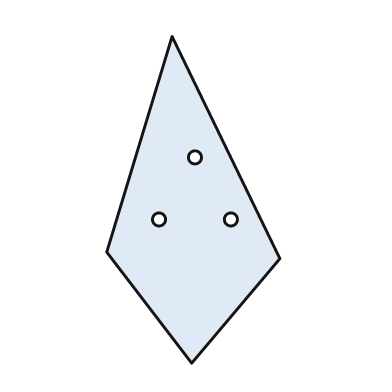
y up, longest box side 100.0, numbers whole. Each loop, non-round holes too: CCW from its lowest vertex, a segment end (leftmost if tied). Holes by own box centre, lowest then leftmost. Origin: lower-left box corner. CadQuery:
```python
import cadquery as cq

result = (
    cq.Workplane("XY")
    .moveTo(26.0, 0.0)
    .lineTo(53.0, 32.0)
    .lineTo(20.0, 100.0)
    .lineTo(0.0, 34.0)
    .close()
    .moveTo(16.0, 44.0)
    .circle(2.0)
    .moveTo(38.0, 44.0)
    .circle(2.0)
    .moveTo(27.0, 63.0)
    .circle(2.0)
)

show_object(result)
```